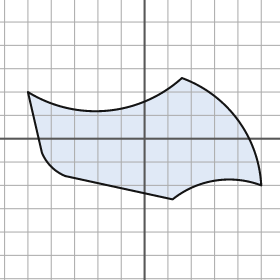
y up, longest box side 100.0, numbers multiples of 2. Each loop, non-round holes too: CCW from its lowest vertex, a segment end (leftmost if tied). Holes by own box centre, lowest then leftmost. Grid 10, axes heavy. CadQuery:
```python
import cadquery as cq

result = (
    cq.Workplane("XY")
    .moveTo(12.0, -26.0)
    .threePointArc((30.0, -18.0), (50.0, -20.0))
    .threePointArc((40.0, 8.0), (16.0, 26.0))
    .threePointArc((-16.0, 12.0), (-50.0, 20.0))
    .lineTo(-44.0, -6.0)
    .threePointArc((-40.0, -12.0), (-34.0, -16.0))
    .close()
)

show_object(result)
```